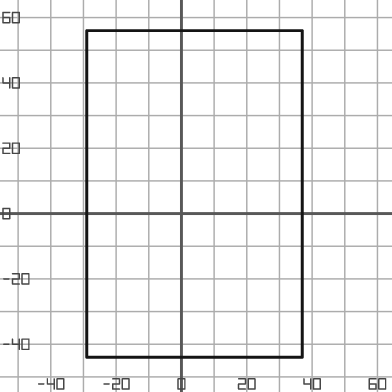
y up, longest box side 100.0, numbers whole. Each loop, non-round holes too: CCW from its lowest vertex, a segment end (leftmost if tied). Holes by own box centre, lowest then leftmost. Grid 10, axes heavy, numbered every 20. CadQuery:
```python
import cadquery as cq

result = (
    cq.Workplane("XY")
    .moveTo(-29.0, -44.0)
    .lineTo(37.0, -44.0)
    .lineTo(37.0, 56.0)
    .lineTo(-29.0, 56.0)
    .close()
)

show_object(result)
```